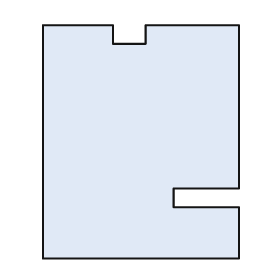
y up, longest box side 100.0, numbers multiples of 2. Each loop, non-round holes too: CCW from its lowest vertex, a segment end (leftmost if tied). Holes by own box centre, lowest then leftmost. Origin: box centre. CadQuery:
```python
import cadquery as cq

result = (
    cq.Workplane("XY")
    .moveTo(-42.0, -50.0)
    .lineTo(42.0, -50.0)
    .lineTo(42.0, -28.0)
    .lineTo(14.0, -28.0)
    .lineTo(14.0, -20.0)
    .lineTo(42.0, -20.0)
    .lineTo(42.0, 50.0)
    .lineTo(2.0, 50.0)
    .lineTo(2.0, 42.0)
    .lineTo(-12.0, 42.0)
    .lineTo(-12.0, 50.0)
    .lineTo(-42.0, 50.0)
    .close()
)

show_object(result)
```